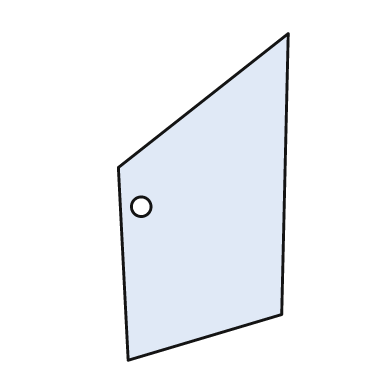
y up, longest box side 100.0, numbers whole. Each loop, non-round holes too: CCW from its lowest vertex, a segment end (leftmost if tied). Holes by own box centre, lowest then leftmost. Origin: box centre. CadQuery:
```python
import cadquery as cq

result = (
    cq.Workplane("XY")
    .moveTo(-23.0, -50.0)
    .lineTo(24.0, -36.0)
    .lineTo(26.0, 50.0)
    .lineTo(-26.0, 9.0)
    .close()
    .moveTo(-19.0, -3.0)
    .circle(3.0)
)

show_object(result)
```